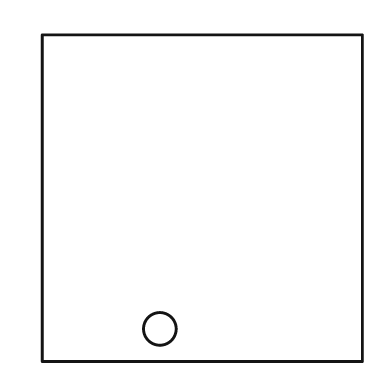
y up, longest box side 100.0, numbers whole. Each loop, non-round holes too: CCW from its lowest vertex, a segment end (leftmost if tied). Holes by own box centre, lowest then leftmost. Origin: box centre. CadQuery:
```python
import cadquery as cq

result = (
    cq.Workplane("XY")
    .moveTo(-49.0, -50.0)
    .lineTo(49.0, -50.0)
    .lineTo(49.0, 50.0)
    .lineTo(-49.0, 50.0)
    .close()
    .moveTo(-13.0, -40.0)
    .circle(5.0)
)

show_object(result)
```